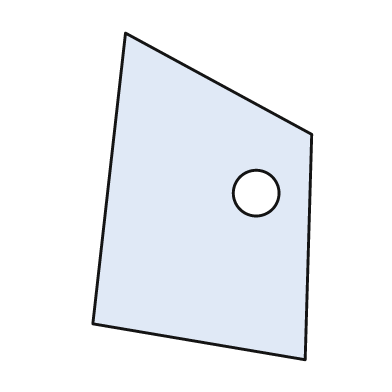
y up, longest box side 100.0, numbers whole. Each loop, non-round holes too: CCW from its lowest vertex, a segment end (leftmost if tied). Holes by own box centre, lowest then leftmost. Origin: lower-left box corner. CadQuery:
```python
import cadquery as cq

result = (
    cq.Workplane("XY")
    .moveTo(65.0, 0.0)
    .lineTo(67.0, 69.0)
    .lineTo(10.0, 100.0)
    .lineTo(0.0, 11.0)
    .close()
    .moveTo(50.0, 51.0)
    .circle(7.0)
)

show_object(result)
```